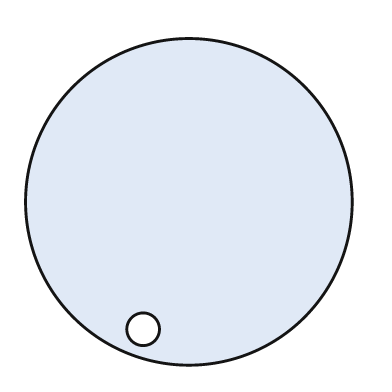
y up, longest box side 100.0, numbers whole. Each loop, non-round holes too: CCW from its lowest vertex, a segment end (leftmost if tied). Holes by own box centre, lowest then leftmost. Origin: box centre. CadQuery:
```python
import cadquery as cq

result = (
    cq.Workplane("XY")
    .moveTo(0.0, 0.0)
    .circle(50.0)
    .moveTo(-14.0, -39.0)
    .circle(5.0)
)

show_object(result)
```